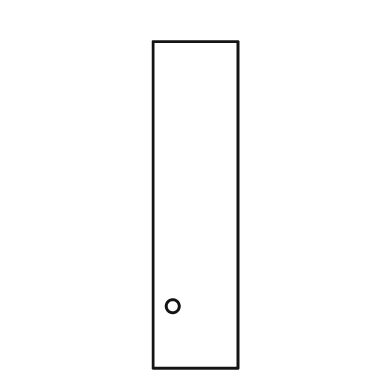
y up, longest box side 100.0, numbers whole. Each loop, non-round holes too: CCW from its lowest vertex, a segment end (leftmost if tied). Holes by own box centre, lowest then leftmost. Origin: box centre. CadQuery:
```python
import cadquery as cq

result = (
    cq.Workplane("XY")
    .moveTo(-13.0, -50.0)
    .lineTo(13.0, -50.0)
    .lineTo(13.0, 50.0)
    .lineTo(-13.0, 50.0)
    .close()
    .moveTo(-7.0, -31.0)
    .circle(2.0)
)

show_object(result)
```